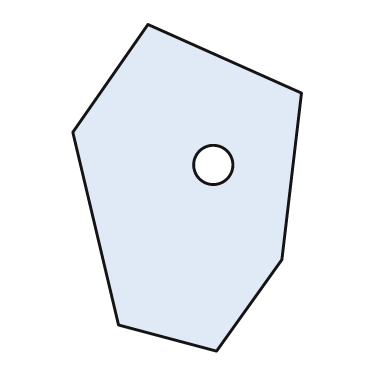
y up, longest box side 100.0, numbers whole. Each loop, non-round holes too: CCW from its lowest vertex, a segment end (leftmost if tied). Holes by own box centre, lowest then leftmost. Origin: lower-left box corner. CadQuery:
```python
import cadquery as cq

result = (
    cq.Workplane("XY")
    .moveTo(44.0, 0.0)
    .lineTo(64.0, 28.0)
    .lineTo(70.0, 79.0)
    .lineTo(23.0, 100.0)
    .lineTo(0.0, 67.0)
    .lineTo(14.0, 8.0)
    .close()
    .moveTo(43.0, 57.0)
    .circle(6.0)
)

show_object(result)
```